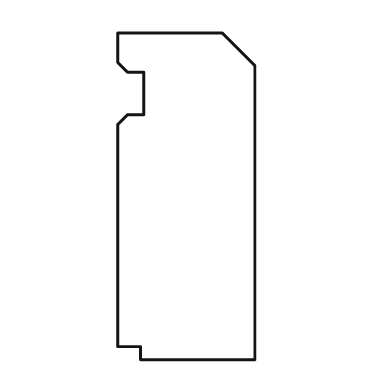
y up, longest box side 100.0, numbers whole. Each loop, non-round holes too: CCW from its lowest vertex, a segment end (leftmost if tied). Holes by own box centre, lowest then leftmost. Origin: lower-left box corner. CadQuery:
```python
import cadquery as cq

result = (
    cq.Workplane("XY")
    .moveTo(7.0, 0.0)
    .lineTo(42.0, 0.0)
    .lineTo(42.0, 90.0)
    .lineTo(32.0, 100.0)
    .lineTo(0.0, 100.0)
    .lineTo(0.0, 91.0)
    .lineTo(3.0, 88.0)
    .lineTo(8.0, 88.0)
    .lineTo(8.0, 75.0)
    .lineTo(3.0, 75.0)
    .lineTo(0.0, 72.0)
    .lineTo(0.0, 4.0)
    .lineTo(7.0, 4.0)
    .close()
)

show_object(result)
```